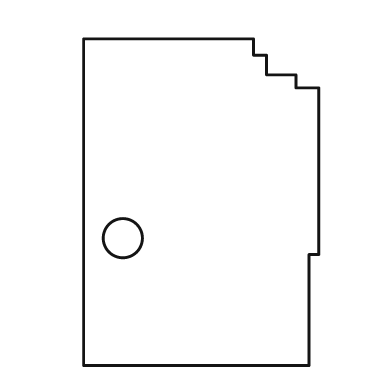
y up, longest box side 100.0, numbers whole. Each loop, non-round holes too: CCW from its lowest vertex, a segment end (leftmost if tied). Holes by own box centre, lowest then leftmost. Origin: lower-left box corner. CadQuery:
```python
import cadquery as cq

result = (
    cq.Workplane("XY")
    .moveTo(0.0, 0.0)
    .lineTo(69.0, 0.0)
    .lineTo(69.0, 34.0)
    .lineTo(72.0, 34.0)
    .lineTo(72.0, 85.0)
    .lineTo(65.0, 85.0)
    .lineTo(65.0, 89.0)
    .lineTo(56.0, 89.0)
    .lineTo(56.0, 95.0)
    .lineTo(52.0, 95.0)
    .lineTo(52.0, 100.0)
    .lineTo(0.0, 100.0)
    .close()
    .moveTo(12.0, 39.0)
    .circle(6.0)
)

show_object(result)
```